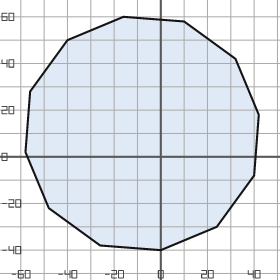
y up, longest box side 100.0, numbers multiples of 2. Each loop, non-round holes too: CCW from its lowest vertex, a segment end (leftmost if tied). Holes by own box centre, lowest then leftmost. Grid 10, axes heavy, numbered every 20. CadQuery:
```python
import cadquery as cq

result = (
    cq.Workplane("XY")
    .moveTo(0.0, -40.0)
    .lineTo(24.0, -30.0)
    .lineTo(40.0, -8.0)
    .lineTo(42.0, 18.0)
    .lineTo(32.0, 42.0)
    .lineTo(10.0, 58.0)
    .lineTo(-16.0, 60.0)
    .lineTo(-40.0, 50.0)
    .lineTo(-56.0, 28.0)
    .lineTo(-58.0, 2.0)
    .lineTo(-48.0, -22.0)
    .lineTo(-26.0, -38.0)
    .close()
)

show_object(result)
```